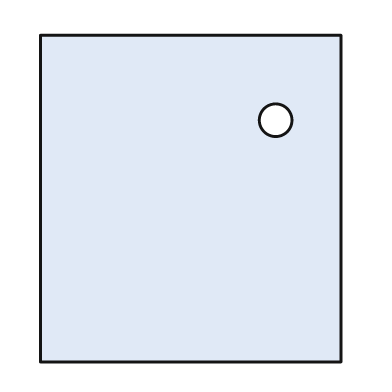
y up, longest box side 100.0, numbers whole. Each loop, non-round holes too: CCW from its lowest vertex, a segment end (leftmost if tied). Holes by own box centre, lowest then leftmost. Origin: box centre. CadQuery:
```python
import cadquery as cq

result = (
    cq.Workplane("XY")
    .moveTo(-46.0, -50.0)
    .lineTo(46.0, -50.0)
    .lineTo(46.0, 50.0)
    .lineTo(-46.0, 50.0)
    .close()
    .moveTo(26.0, 24.0)
    .circle(5.0)
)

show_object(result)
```